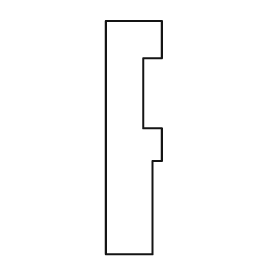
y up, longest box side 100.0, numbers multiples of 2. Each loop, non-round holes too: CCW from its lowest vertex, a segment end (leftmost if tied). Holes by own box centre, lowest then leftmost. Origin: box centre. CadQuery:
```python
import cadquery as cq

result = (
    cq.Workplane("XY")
    .moveTo(-12.0, -50.0)
    .lineTo(8.0, -50.0)
    .lineTo(8.0, -10.0)
    .lineTo(12.0, -10.0)
    .lineTo(12.0, 4.0)
    .lineTo(4.0, 4.0)
    .lineTo(4.0, 34.0)
    .lineTo(12.0, 34.0)
    .lineTo(12.0, 50.0)
    .lineTo(-12.0, 50.0)
    .close()
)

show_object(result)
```